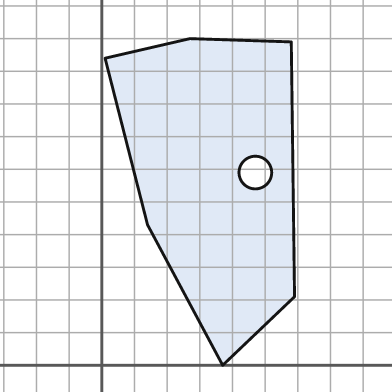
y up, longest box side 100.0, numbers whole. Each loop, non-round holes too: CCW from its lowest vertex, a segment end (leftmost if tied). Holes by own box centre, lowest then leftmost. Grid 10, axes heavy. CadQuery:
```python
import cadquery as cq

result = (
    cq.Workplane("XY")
    .moveTo(37.0, 0.0)
    .lineTo(59.0, 21.0)
    .lineTo(58.0, 99.0)
    .lineTo(27.0, 100.0)
    .lineTo(1.0, 94.0)
    .lineTo(14.0, 43.0)
    .close()
    .moveTo(47.0, 59.0)
    .circle(5.0)
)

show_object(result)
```